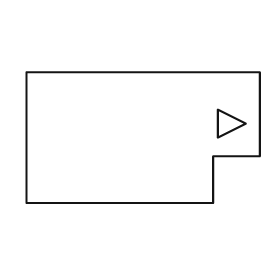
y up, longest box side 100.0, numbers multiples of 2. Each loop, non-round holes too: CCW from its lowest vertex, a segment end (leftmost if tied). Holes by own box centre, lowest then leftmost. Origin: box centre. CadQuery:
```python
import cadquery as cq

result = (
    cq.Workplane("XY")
    .moveTo(-50.0, -28.0)
    .lineTo(30.0, -28.0)
    .lineTo(30.0, -8.0)
    .lineTo(50.0, -8.0)
    .lineTo(50.0, 28.0)
    .lineTo(-50.0, 28.0)
    .close()
    .moveTo(32.0, 0.0)
    .lineTo(44.0, 6.0)
    .lineTo(32.0, 12.0)
    .close()
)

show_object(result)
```